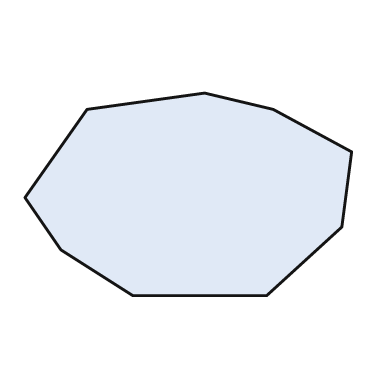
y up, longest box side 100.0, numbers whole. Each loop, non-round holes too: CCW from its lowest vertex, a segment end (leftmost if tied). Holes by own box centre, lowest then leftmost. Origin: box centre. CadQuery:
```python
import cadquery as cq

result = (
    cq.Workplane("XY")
    .moveTo(-17.0, -31.0)
    .lineTo(24.0, -31.0)
    .lineTo(47.0, -10.0)
    .lineTo(50.0, 13.0)
    .lineTo(26.0, 26.0)
    .lineTo(5.0, 31.0)
    .lineTo(-31.0, 26.0)
    .lineTo(-50.0, -1.0)
    .lineTo(-39.0, -17.0)
    .close()
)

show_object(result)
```